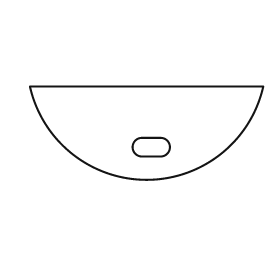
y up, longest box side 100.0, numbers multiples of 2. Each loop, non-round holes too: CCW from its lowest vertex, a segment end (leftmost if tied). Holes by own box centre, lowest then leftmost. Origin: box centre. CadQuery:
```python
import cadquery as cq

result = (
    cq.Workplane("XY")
    .moveTo(-50.0, 20.0)
    .threePointArc((0.0, -20.0), (50.0, 20.0))
    .close()
    .moveTo(-2.0, -10.0)
    .lineTo(6.0, -10.0)
    .threePointArc((10.0, -6.0), (6.0, -2.0))
    .lineTo(-2.0, -2.0)
    .threePointArc((-6.0, -6.0), (-2.0, -10.0))
    .close()
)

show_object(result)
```